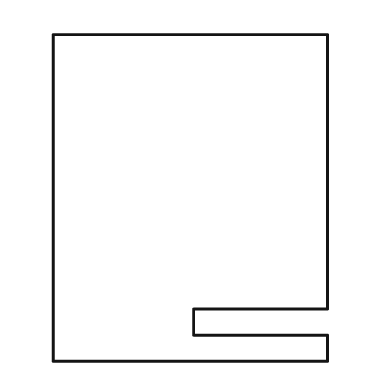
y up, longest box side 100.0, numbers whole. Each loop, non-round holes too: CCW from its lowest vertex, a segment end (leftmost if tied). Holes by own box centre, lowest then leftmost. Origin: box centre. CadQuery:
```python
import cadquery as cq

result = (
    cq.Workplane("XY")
    .moveTo(-42.0, -50.0)
    .lineTo(42.0, -50.0)
    .lineTo(42.0, -42.0)
    .lineTo(1.0, -42.0)
    .lineTo(1.0, -34.0)
    .lineTo(42.0, -34.0)
    .lineTo(42.0, 50.0)
    .lineTo(-42.0, 50.0)
    .close()
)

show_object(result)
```